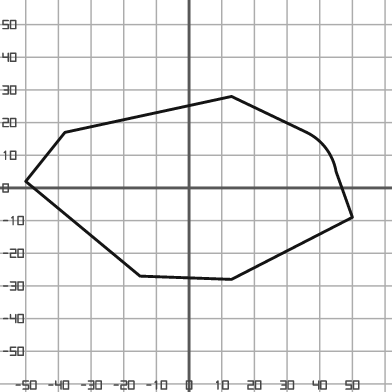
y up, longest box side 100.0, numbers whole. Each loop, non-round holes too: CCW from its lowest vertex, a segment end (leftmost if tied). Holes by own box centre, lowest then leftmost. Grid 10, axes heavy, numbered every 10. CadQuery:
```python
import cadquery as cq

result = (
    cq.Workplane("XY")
    .moveTo(13.0, -28.0)
    .lineTo(50.0, -9.0)
    .lineTo(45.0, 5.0)
    .threePointArc((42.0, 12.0), (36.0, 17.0))
    .lineTo(13.0, 28.0)
    .lineTo(-38.0, 17.0)
    .lineTo(-50.0, 2.0)
    .lineTo(-15.0, -27.0)
    .close()
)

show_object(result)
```